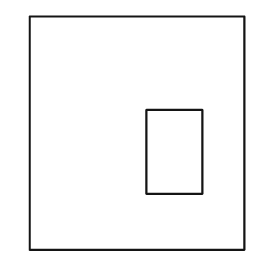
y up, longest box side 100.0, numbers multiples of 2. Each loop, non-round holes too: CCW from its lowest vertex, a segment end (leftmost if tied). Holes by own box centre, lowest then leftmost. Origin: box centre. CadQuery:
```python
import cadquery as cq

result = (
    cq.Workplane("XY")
    .moveTo(-46.0, -50.0)
    .lineTo(46.0, -50.0)
    .lineTo(46.0, 50.0)
    .lineTo(-46.0, 50.0)
    .close()
    .moveTo(4.0, -26.0)
    .lineTo(28.0, -26.0)
    .lineTo(28.0, 10.0)
    .lineTo(4.0, 10.0)
    .close()
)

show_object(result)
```